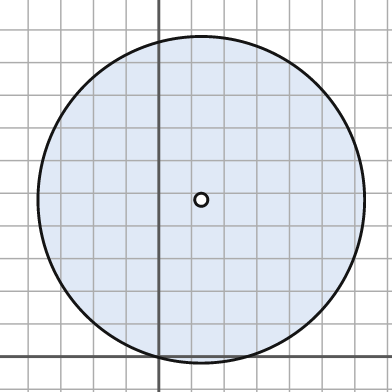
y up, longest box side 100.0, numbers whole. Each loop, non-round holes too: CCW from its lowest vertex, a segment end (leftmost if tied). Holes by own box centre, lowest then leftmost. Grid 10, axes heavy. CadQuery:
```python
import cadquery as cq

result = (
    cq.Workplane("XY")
    .moveTo(13.0, 48.0)
    .circle(50.0)
    .moveTo(13.0, 48.0)
    .circle(2.0)
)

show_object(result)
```